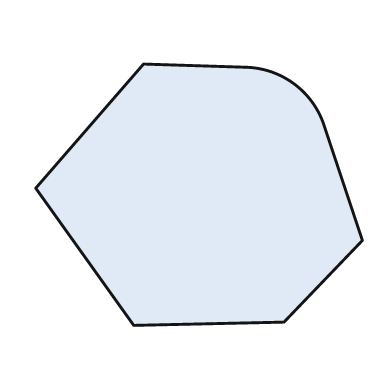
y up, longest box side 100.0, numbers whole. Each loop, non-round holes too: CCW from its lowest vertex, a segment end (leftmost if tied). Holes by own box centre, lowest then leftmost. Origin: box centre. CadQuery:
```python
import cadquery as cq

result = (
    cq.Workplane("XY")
    .moveTo(-20.0, -40.0)
    .lineTo(26.0, -39.0)
    .lineTo(50.0, -14.0)
    .lineTo(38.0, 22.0)
    .threePointArc((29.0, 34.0), (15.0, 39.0))
    .lineTo(-17.0, 40.0)
    .lineTo(-50.0, 2.0)
    .close()
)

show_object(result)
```